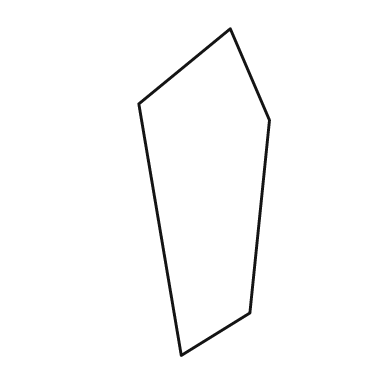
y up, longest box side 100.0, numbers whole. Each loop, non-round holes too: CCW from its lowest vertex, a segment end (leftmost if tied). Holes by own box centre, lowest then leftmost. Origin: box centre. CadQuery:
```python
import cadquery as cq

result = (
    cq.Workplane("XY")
    .moveTo(-7.0, -50.0)
    .lineTo(14.0, -37.0)
    .lineTo(20.0, 22.0)
    .lineTo(8.0, 50.0)
    .lineTo(-20.0, 27.0)
    .close()
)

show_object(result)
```